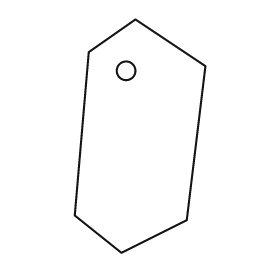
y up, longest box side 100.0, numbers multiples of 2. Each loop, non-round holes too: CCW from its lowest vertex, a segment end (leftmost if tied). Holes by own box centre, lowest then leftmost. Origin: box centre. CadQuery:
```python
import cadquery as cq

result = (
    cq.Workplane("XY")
    .moveTo(-8.0, -50.0)
    .lineTo(20.0, -36.0)
    .lineTo(28.0, 30.0)
    .lineTo(-2.0, 50.0)
    .lineTo(-22.0, 36.0)
    .lineTo(-28.0, -34.0)
    .close()
    .moveTo(-6.0, 28.0)
    .circle(4.0)
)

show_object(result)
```